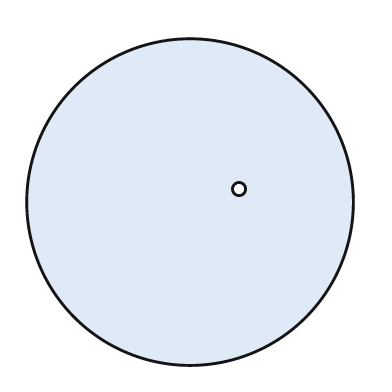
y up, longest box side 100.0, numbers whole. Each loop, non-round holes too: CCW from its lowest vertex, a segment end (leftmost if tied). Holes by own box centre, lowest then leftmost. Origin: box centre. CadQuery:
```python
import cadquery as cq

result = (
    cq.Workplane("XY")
    .moveTo(0.0, 0.0)
    .circle(50.0)
    .moveTo(15.0, 4.0)
    .circle(2.0)
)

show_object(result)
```